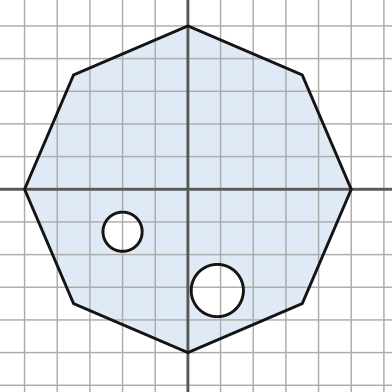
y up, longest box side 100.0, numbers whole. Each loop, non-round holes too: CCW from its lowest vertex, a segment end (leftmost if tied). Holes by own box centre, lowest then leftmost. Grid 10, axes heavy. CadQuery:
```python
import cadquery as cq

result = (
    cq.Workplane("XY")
    .moveTo(0.0, -50.0)
    .lineTo(35.0, -35.0)
    .lineTo(50.0, 0.0)
    .lineTo(35.0, 35.0)
    .lineTo(0.0, 50.0)
    .lineTo(-35.0, 35.0)
    .lineTo(-50.0, 0.0)
    .lineTo(-35.0, -35.0)
    .close()
    .moveTo(9.0, -31.0)
    .circle(8.0)
    .moveTo(-20.0, -13.0)
    .circle(6.0)
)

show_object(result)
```